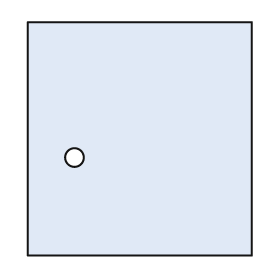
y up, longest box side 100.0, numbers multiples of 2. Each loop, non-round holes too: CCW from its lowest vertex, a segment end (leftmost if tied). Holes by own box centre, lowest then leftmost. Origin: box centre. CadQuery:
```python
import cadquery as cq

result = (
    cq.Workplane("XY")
    .moveTo(-48.0, -50.0)
    .lineTo(48.0, -50.0)
    .lineTo(48.0, 50.0)
    .lineTo(-48.0, 50.0)
    .close()
    .moveTo(-28.0, -8.0)
    .circle(4.0)
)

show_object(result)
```